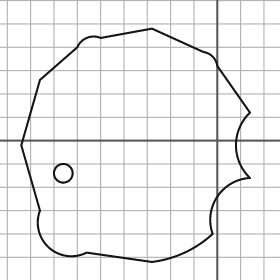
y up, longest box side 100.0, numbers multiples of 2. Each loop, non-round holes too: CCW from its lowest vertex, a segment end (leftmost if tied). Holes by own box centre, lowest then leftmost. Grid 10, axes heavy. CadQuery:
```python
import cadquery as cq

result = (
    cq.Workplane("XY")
    .moveTo(-28.0, -52.0)
    .threePointArc((-14.0, -48.0), (-2.0, -40.0))
    .threePointArc((0.0, -24.0), (14.0, -16.0))
    .threePointArc((8.0, -2.0), (14.0, 12.0))
    .lineTo(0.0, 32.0)
    .threePointArc((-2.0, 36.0), (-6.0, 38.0))
    .lineTo(-28.0, 48.0)
    .lineTo(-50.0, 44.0)
    .threePointArc((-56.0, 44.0), (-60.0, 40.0))
    .lineTo(-76.0, 26.0)
    .lineTo(-84.0, -2.0)
    .lineTo(-76.0, -30.0)
    .threePointArc((-72.0, -46.0), (-56.0, -48.0))
    .close()
    .moveTo(-66.0, -14.0)
    .circle(4.0)
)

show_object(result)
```